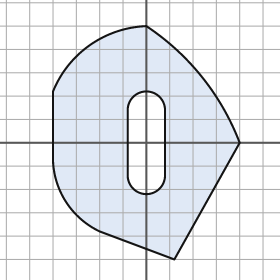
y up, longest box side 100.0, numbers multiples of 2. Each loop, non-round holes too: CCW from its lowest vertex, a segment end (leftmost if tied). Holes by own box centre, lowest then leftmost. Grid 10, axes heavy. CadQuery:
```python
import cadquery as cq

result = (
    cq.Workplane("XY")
    .moveTo(12.0, -50.0)
    .lineTo(40.0, 0.0)
    .threePointArc((24.0, 28.0), (0.0, 50.0))
    .threePointArc((-24.0, 42.0), (-40.0, 22.0))
    .lineTo(-40.0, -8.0)
    .threePointArc((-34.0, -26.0), (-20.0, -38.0))
    .close()
    .moveTo(-8.0, -14.0)
    .threePointArc((0.0, -22.0), (8.0, -14.0))
    .lineTo(8.0, 14.0)
    .threePointArc((0.0, 22.0), (-8.0, 14.0))
    .close()
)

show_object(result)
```